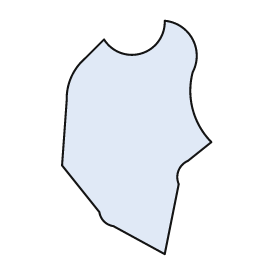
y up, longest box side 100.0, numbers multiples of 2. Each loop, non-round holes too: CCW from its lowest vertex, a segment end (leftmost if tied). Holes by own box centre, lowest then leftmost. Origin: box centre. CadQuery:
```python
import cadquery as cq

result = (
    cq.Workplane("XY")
    .moveTo(12.0, -50.0)
    .lineTo(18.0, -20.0)
    .threePointArc((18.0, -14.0), (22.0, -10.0))
    .lineTo(32.0, -2.0)
    .threePointArc((24.0, 12.0), (24.0, 28.0))
    .threePointArc((24.0, 42.0), (12.0, 50.0))
    .threePointArc((2.0, 36.0), (-14.0, 42.0))
    .lineTo(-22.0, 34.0)
    .threePointArc((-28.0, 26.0), (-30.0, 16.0))
    .lineTo(-32.0, -12.0)
    .lineTo(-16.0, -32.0)
    .threePointArc((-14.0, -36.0), (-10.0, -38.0))
    .close()
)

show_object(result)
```